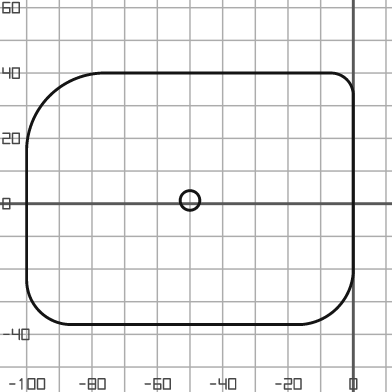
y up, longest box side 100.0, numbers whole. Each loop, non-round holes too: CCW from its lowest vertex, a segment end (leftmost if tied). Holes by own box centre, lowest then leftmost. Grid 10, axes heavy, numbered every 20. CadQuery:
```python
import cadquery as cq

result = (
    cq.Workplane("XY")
    .moveTo(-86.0, -37.0)
    .lineTo(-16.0, -37.0)
    .threePointArc((-5.0, -32.0), (0.0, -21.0))
    .lineTo(0.0, 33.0)
    .threePointArc((-2.0, 38.0), (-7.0, 40.0))
    .lineTo(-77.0, 40.0)
    .threePointArc((-93.0, 33.0), (-100.0, 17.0))
    .lineTo(-100.0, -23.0)
    .threePointArc((-96.0, -33.0), (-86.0, -37.0))
    .close()
    .moveTo(-50.0, 1.0)
    .circle(3.0)
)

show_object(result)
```